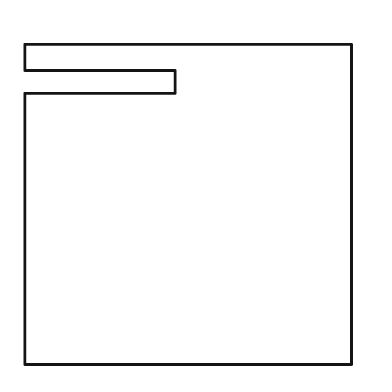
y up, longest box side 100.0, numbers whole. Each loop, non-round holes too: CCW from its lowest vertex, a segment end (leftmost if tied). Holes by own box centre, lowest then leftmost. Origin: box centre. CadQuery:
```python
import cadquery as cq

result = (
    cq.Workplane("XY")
    .moveTo(-50.0, -49.0)
    .lineTo(50.0, -49.0)
    .lineTo(50.0, 49.0)
    .lineTo(-50.0, 49.0)
    .lineTo(-50.0, 41.0)
    .lineTo(-4.0, 41.0)
    .lineTo(-4.0, 34.0)
    .lineTo(-50.0, 34.0)
    .close()
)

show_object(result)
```